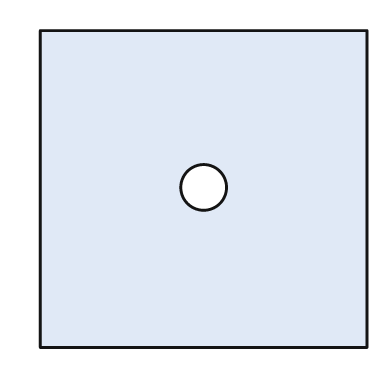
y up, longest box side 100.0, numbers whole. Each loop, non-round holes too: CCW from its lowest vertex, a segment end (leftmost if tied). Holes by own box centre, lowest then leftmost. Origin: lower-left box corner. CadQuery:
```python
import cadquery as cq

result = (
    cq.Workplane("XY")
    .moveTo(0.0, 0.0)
    .lineTo(100.0, 0.0)
    .lineTo(100.0, 97.0)
    .lineTo(0.0, 97.0)
    .close()
    .moveTo(50.0, 49.0)
    .circle(7.0)
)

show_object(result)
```